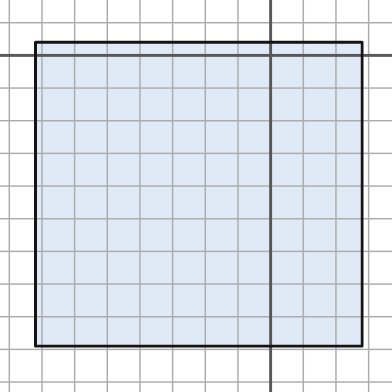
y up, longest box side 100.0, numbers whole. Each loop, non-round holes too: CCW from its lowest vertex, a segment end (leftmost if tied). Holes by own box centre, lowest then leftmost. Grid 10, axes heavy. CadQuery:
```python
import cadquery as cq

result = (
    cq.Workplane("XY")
    .moveTo(-72.0, -89.0)
    .lineTo(28.0, -89.0)
    .lineTo(28.0, 4.0)
    .lineTo(-72.0, 4.0)
    .close()
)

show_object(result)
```